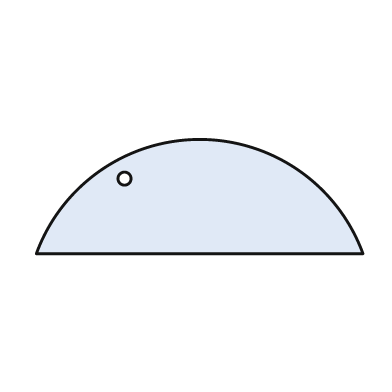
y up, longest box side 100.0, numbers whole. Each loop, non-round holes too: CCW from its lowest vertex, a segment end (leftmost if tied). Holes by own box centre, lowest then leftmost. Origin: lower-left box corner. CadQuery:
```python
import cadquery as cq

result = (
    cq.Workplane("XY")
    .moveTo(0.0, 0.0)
    .lineTo(100.0, 0.0)
    .threePointArc((50.0, 35.0), (0.0, 0.0))
    .close()
    .moveTo(27.0, 23.0)
    .circle(2.0)
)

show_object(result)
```